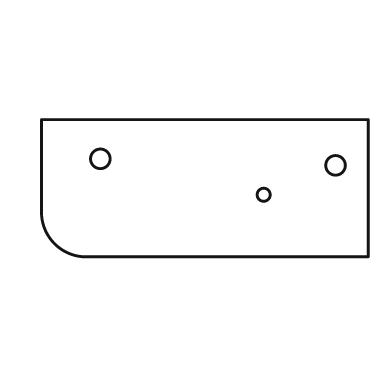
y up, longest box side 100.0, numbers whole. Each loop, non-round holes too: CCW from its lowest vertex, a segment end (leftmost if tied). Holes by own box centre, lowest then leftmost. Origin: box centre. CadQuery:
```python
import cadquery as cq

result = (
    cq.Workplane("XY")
    .moveTo(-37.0, -21.0)
    .lineTo(50.0, -21.0)
    .lineTo(50.0, 21.0)
    .lineTo(-50.0, 21.0)
    .lineTo(-50.0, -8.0)
    .threePointArc((-46.0, -17.0), (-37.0, -21.0))
    .close()
    .moveTo(18.0, -2.0)
    .circle(2.0)
    .moveTo(40.0, 7.0)
    .circle(3.0)
    .moveTo(-32.0, 9.0)
    .circle(3.0)
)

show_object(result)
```